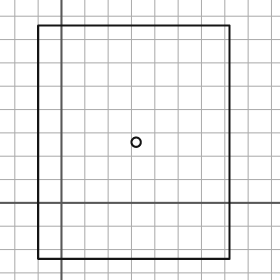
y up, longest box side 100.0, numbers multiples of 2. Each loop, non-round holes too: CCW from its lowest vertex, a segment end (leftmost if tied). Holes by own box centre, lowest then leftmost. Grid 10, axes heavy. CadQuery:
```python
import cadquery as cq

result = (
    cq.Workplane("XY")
    .moveTo(-10.0, -24.0)
    .lineTo(72.0, -24.0)
    .lineTo(72.0, 76.0)
    .lineTo(-10.0, 76.0)
    .close()
    .moveTo(32.0, 26.0)
    .circle(2.0)
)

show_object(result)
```